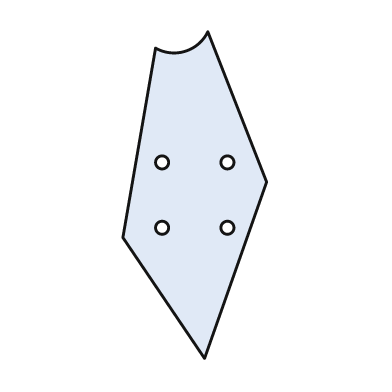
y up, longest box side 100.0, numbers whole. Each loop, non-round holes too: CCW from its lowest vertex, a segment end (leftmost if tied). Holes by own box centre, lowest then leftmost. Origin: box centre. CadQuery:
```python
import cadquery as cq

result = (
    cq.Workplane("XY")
    .moveTo(3.0, -50.0)
    .lineTo(22.0, 4.0)
    .lineTo(4.0, 50.0)
    .threePointArc((-3.0, 44.0), (-12.0, 45.0))
    .lineTo(-22.0, -13.0)
    .close()
    .moveTo(-10.0, -10.0)
    .circle(2.0)
    .moveTo(10.0, -10.0)
    .circle(2.0)
    .moveTo(-10.0, 10.0)
    .circle(2.0)
    .moveTo(10.0, 10.0)
    .circle(2.0)
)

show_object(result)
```